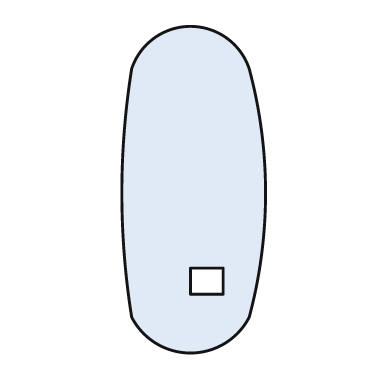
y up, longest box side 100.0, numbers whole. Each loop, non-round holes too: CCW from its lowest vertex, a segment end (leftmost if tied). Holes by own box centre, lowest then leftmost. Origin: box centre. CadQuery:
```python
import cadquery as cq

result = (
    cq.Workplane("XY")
    .moveTo(-19.0, -39.0)
    .threePointArc((-1.0, -50.0), (17.0, -39.0))
    .threePointArc((22.0, -1.0), (17.0, 37.0))
    .threePointArc((-1.0, 50.0), (-19.0, 37.0))
    .threePointArc((-22.0, -1.0), (-19.0, -39.0))
    .close()
    .moveTo(-1.0, -32.0)
    .lineTo(9.0, -32.0)
    .lineTo(9.0, -24.0)
    .lineTo(-1.0, -24.0)
    .close()
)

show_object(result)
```